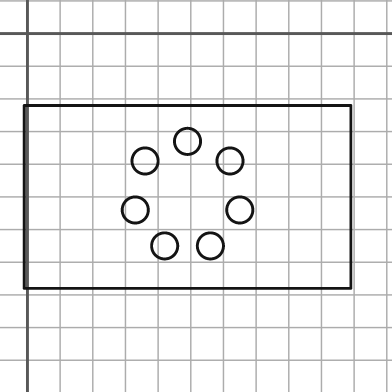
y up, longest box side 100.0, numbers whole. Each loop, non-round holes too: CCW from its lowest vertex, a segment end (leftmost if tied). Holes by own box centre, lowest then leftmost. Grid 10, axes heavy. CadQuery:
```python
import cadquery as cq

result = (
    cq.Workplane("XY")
    .moveTo(-1.0, -78.0)
    .lineTo(99.0, -78.0)
    .lineTo(99.0, -22.0)
    .lineTo(-1.0, -22.0)
    .close()
    .moveTo(42.0, -65.0)
    .circle(4.0)
    .moveTo(56.0, -65.0)
    .circle(4.0)
    .moveTo(33.0, -54.0)
    .circle(4.0)
    .moveTo(65.0, -54.0)
    .circle(4.0)
    .moveTo(36.0, -39.0)
    .circle(4.0)
    .moveTo(62.0, -39.0)
    .circle(4.0)
    .moveTo(49.0, -33.0)
    .circle(4.0)
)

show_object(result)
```